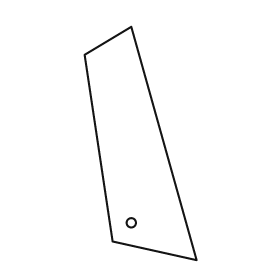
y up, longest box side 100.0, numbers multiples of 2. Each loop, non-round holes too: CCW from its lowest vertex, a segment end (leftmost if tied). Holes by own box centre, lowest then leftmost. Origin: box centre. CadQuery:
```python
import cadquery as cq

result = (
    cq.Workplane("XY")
    .moveTo(24.0, -50.0)
    .lineTo(-4.0, 50.0)
    .lineTo(-24.0, 38.0)
    .lineTo(-12.0, -42.0)
    .close()
    .moveTo(-4.0, -34.0)
    .circle(2.0)
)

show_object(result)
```